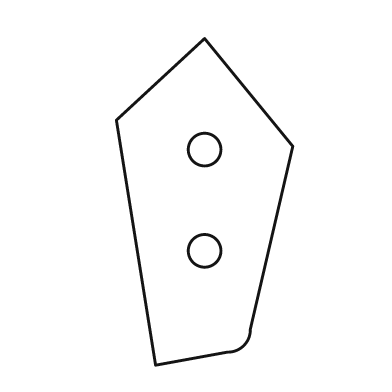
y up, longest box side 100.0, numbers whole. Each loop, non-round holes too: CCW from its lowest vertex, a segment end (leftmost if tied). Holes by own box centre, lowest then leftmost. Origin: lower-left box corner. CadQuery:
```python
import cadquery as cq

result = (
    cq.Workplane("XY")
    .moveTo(12.0, 0.0)
    .lineTo(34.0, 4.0)
    .threePointArc((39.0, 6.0), (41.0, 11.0))
    .lineTo(54.0, 67.0)
    .lineTo(27.0, 100.0)
    .lineTo(0.0, 75.0)
    .close()
    .moveTo(27.0, 35.0)
    .circle(5.0)
    .moveTo(27.0, 66.0)
    .circle(5.0)
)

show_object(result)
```